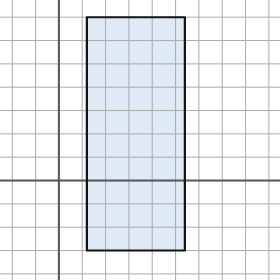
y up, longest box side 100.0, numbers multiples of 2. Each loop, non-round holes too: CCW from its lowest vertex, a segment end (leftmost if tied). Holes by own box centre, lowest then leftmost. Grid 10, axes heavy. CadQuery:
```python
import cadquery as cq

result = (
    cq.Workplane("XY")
    .moveTo(12.0, -30.0)
    .lineTo(54.0, -30.0)
    .lineTo(54.0, 70.0)
    .lineTo(12.0, 70.0)
    .close()
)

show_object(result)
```